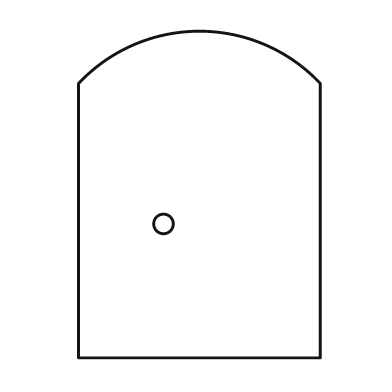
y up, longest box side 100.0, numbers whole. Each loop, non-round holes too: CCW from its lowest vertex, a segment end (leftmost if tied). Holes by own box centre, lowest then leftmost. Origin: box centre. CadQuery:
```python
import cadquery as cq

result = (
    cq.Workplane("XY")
    .moveTo(-37.0, -50.0)
    .lineTo(37.0, -50.0)
    .lineTo(37.0, 34.0)
    .threePointArc((0.0, 50.0), (-37.0, 34.0))
    .close()
    .moveTo(-11.0, -9.0)
    .circle(3.0)
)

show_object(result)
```